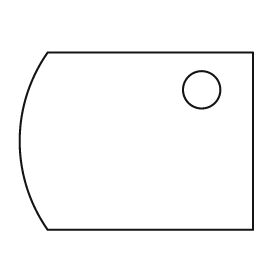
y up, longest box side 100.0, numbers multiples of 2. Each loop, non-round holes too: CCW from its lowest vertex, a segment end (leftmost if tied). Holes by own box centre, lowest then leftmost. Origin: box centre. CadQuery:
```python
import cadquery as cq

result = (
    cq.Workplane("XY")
    .moveTo(-38.0, -38.0)
    .lineTo(50.0, -38.0)
    .lineTo(50.0, 38.0)
    .lineTo(-38.0, 38.0)
    .threePointArc((-50.0, 0.0), (-38.0, -38.0))
    .close()
    .moveTo(28.0, 22.0)
    .circle(8.0)
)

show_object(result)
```